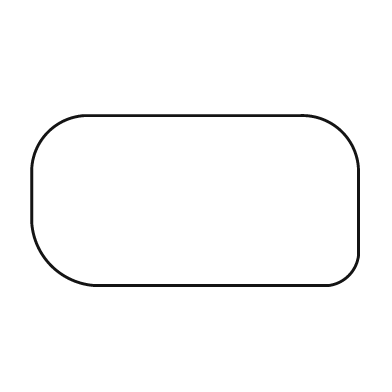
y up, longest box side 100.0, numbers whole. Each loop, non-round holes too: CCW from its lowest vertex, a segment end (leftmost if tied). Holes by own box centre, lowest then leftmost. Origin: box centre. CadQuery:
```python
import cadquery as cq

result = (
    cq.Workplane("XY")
    .moveTo(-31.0, -26.0)
    .lineTo(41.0, -26.0)
    .threePointArc((47.0, -23.0), (50.0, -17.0))
    .lineTo(50.0, 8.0)
    .threePointArc((45.0, 21.0), (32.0, 26.0))
    .lineTo(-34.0, 26.0)
    .threePointArc((-45.0, 21.0), (-50.0, 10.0))
    .lineTo(-50.0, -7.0)
    .threePointArc((-44.0, -20.0), (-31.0, -26.0))
    .close()
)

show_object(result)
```